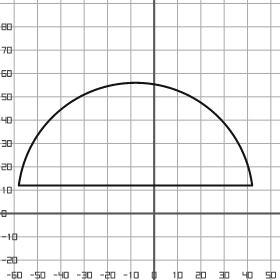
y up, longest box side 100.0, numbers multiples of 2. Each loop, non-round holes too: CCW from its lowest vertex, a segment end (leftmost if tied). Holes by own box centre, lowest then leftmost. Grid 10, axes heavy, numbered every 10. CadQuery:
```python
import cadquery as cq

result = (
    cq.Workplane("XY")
    .moveTo(-58.0, 12.0)
    .lineTo(42.0, 12.0)
    .threePointArc((-8.0, 56.0), (-58.0, 12.0))
    .close()
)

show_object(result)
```